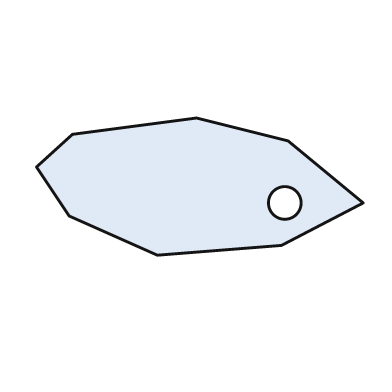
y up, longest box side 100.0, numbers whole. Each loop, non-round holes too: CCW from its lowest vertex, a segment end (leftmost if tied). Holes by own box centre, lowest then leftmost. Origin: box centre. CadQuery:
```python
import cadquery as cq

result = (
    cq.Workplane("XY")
    .moveTo(-13.0, -21.0)
    .lineTo(25.0, -18.0)
    .lineTo(50.0, -5.0)
    .lineTo(27.0, 14.0)
    .lineTo(-1.0, 21.0)
    .lineTo(-39.0, 16.0)
    .lineTo(-50.0, 6.0)
    .lineTo(-40.0, -9.0)
    .close()
    .moveTo(26.0, -5.0)
    .circle(5.0)
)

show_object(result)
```